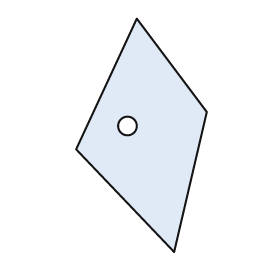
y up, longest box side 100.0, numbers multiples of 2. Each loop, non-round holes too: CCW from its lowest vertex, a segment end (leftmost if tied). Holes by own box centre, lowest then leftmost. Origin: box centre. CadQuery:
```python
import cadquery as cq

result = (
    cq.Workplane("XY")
    .moveTo(14.0, -50.0)
    .lineTo(28.0, 10.0)
    .lineTo(-2.0, 50.0)
    .lineTo(-28.0, -6.0)
    .close()
    .moveTo(-6.0, 4.0)
    .circle(4.0)
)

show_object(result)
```